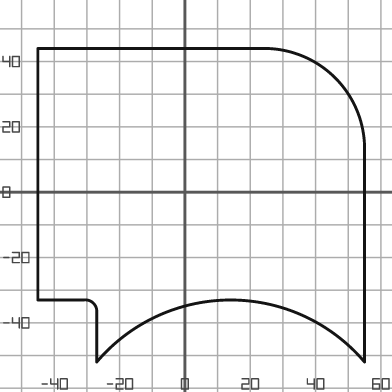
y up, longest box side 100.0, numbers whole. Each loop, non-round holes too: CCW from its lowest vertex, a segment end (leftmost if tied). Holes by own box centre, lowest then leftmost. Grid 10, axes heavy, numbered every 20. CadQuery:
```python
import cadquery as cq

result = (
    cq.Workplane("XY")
    .moveTo(-27.0, -52.0)
    .threePointArc((14.0, -33.0), (55.0, -52.0))
    .lineTo(55.0, 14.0)
    .threePointArc((46.0, 35.0), (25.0, 44.0))
    .lineTo(-45.0, 44.0)
    .lineTo(-45.0, -33.0)
    .lineTo(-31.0, -33.0)
    .threePointArc((-28.0, -34.0), (-27.0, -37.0))
    .close()
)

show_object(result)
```